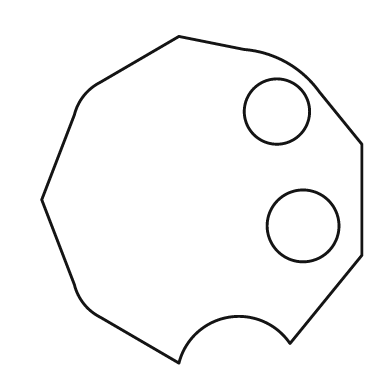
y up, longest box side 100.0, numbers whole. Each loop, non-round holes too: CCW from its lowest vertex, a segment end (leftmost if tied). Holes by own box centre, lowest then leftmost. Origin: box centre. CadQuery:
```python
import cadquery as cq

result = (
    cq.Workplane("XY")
    .moveTo(-7.0, -50.0)
    .threePointArc((8.0, -36.0), (27.0, -44.0))
    .lineTo(49.0, -17.0)
    .lineTo(49.0, 17.0)
    .lineTo(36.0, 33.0)
    .threePointArc((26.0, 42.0), (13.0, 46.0))
    .lineTo(-7.0, 50.0)
    .lineTo(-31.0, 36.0)
    .threePointArc((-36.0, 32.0), (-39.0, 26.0))
    .lineTo(-49.0, 0.0)
    .lineTo(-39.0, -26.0)
    .threePointArc((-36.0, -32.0), (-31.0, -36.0))
    .close()
    .moveTo(31.0, -8.0)
    .circle(11.0)
    .moveTo(23.0, 27.0)
    .circle(10.0)
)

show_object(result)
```